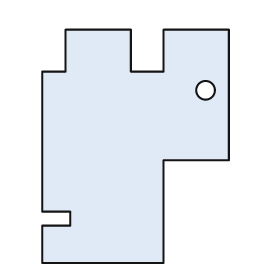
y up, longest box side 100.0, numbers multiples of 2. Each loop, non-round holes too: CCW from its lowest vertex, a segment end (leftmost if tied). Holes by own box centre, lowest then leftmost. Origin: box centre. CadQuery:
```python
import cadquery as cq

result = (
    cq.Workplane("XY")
    .moveTo(-40.0, -50.0)
    .lineTo(12.0, -50.0)
    .lineTo(12.0, -6.0)
    .lineTo(40.0, -6.0)
    .lineTo(40.0, 50.0)
    .lineTo(12.0, 50.0)
    .lineTo(12.0, 32.0)
    .lineTo(-2.0, 32.0)
    .lineTo(-2.0, 50.0)
    .lineTo(-30.0, 50.0)
    .lineTo(-30.0, 32.0)
    .lineTo(-40.0, 32.0)
    .lineTo(-40.0, -28.0)
    .lineTo(-28.0, -28.0)
    .lineTo(-28.0, -34.0)
    .lineTo(-40.0, -34.0)
    .close()
    .moveTo(30.0, 24.0)
    .circle(4.0)
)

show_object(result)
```